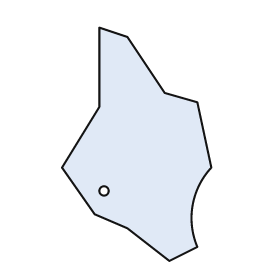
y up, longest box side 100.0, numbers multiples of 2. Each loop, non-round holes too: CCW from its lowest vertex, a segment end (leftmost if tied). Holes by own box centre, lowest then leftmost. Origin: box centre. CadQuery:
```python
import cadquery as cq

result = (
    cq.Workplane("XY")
    .moveTo(14.0, -50.0)
    .lineTo(26.0, -44.0)
    .threePointArc((24.0, -26.0), (32.0, -10.0))
    .lineTo(26.0, 18.0)
    .lineTo(12.0, 22.0)
    .lineTo(-4.0, 46.0)
    .lineTo(-16.0, 50.0)
    .lineTo(-16.0, 16.0)
    .lineTo(-32.0, -10.0)
    .lineTo(-18.0, -30.0)
    .lineTo(-4.0, -36.0)
    .close()
    .moveTo(-14.0, -20.0)
    .circle(2.0)
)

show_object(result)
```